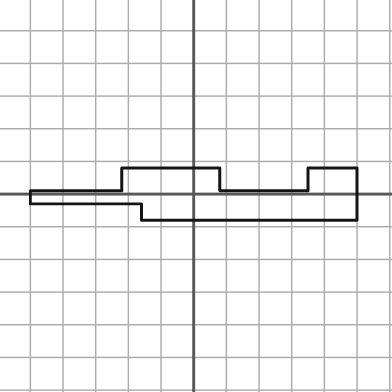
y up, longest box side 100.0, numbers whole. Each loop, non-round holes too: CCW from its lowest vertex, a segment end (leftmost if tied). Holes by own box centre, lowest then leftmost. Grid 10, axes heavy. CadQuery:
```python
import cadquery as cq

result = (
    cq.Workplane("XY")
    .moveTo(-16.0, -8.0)
    .lineTo(50.0, -8.0)
    .lineTo(50.0, 8.0)
    .lineTo(35.0, 8.0)
    .lineTo(35.0, 1.0)
    .lineTo(8.0, 1.0)
    .lineTo(8.0, 8.0)
    .lineTo(-22.0, 8.0)
    .lineTo(-22.0, 1.0)
    .lineTo(-50.0, 1.0)
    .lineTo(-50.0, -3.0)
    .lineTo(-16.0, -3.0)
    .close()
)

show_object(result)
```